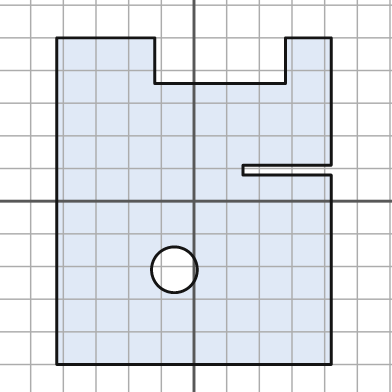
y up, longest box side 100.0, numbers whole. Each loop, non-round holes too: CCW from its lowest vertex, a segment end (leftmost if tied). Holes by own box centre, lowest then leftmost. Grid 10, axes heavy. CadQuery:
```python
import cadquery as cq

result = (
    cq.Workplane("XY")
    .moveTo(-42.0, -50.0)
    .lineTo(42.0, -50.0)
    .lineTo(42.0, 8.0)
    .lineTo(15.0, 8.0)
    .lineTo(15.0, 11.0)
    .lineTo(42.0, 11.0)
    .lineTo(42.0, 50.0)
    .lineTo(28.0, 50.0)
    .lineTo(28.0, 36.0)
    .lineTo(-12.0, 36.0)
    .lineTo(-12.0, 50.0)
    .lineTo(-42.0, 50.0)
    .close()
    .moveTo(-6.0, -21.0)
    .circle(7.0)
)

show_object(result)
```